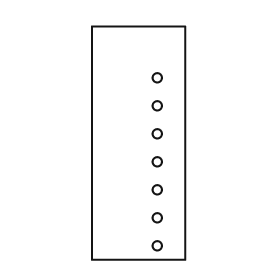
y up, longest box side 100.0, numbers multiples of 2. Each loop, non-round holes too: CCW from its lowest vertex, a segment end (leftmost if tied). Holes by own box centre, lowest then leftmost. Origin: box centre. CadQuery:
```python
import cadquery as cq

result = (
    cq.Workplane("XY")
    .moveTo(-20.0, -50.0)
    .lineTo(20.0, -50.0)
    .lineTo(20.0, 50.0)
    .lineTo(-20.0, 50.0)
    .close()
    .moveTo(8.0, -44.0)
    .circle(2.0)
    .moveTo(8.0, -32.0)
    .circle(2.0)
    .moveTo(8.0, -20.0)
    .circle(2.0)
    .moveTo(8.0, -8.0)
    .circle(2.0)
    .moveTo(8.0, 4.0)
    .circle(2.0)
    .moveTo(8.0, 16.0)
    .circle(2.0)
    .moveTo(8.0, 28.0)
    .circle(2.0)
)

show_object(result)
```